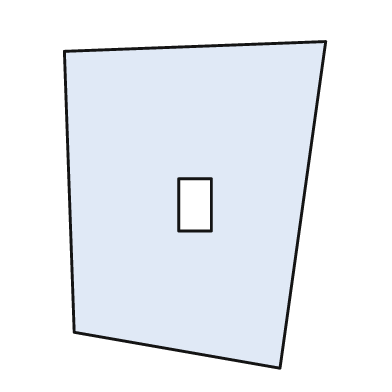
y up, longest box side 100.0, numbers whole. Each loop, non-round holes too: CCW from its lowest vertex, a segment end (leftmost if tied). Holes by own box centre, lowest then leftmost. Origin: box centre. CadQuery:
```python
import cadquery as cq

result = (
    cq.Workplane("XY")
    .moveTo(26.0, -50.0)
    .lineTo(40.0, 50.0)
    .lineTo(-40.0, 47.0)
    .lineTo(-37.0, -39.0)
    .close()
    .moveTo(-5.0, -8.0)
    .lineTo(5.0, -8.0)
    .lineTo(5.0, 8.0)
    .lineTo(-5.0, 8.0)
    .close()
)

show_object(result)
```